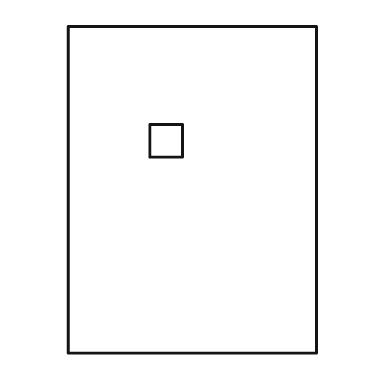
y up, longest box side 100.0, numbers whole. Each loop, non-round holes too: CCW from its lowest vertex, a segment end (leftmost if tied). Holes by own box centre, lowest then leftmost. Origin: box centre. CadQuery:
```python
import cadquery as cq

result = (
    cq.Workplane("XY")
    .moveTo(-38.0, -50.0)
    .lineTo(38.0, -50.0)
    .lineTo(38.0, 50.0)
    .lineTo(-38.0, 50.0)
    .close()
    .moveTo(-13.0, 10.0)
    .lineTo(-3.0, 10.0)
    .lineTo(-3.0, 20.0)
    .lineTo(-13.0, 20.0)
    .close()
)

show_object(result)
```